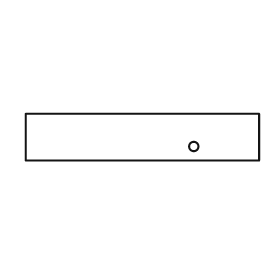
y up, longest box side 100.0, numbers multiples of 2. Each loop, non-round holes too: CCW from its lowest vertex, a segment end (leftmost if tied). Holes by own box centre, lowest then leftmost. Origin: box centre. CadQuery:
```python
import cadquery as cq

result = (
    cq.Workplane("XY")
    .moveTo(-50.0, -10.0)
    .lineTo(50.0, -10.0)
    .lineTo(50.0, 10.0)
    .lineTo(-50.0, 10.0)
    .close()
    .moveTo(22.0, -4.0)
    .circle(2.0)
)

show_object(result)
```